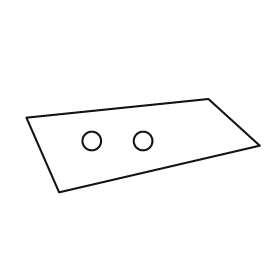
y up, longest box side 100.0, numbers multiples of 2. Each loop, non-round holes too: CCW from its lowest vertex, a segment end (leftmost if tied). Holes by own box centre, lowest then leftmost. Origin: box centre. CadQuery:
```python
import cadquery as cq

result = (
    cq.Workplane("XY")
    .moveTo(-36.0, -20.0)
    .lineTo(50.0, 0.0)
    .lineTo(28.0, 20.0)
    .lineTo(-50.0, 12.0)
    .close()
    .moveTo(-22.0, 2.0)
    .circle(4.0)
    .moveTo(0.0, 2.0)
    .circle(4.0)
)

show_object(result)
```